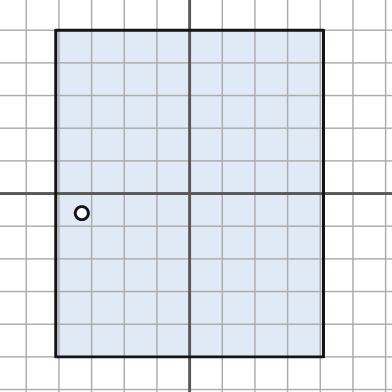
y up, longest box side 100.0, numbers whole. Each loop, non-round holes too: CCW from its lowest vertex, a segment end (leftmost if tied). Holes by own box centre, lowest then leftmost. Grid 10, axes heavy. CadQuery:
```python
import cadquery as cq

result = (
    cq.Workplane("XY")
    .moveTo(-41.0, -50.0)
    .lineTo(41.0, -50.0)
    .lineTo(41.0, 50.0)
    .lineTo(-41.0, 50.0)
    .close()
    .moveTo(-33.0, -6.0)
    .circle(2.0)
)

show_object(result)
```